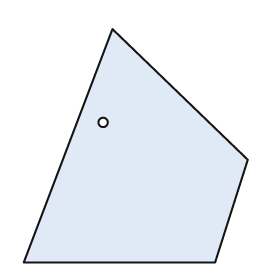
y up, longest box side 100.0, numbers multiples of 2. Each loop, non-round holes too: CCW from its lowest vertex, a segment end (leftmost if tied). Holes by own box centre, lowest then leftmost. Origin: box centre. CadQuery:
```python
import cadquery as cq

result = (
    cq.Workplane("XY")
    .moveTo(-48.0, -50.0)
    .lineTo(34.0, -50.0)
    .lineTo(48.0, -6.0)
    .lineTo(-10.0, 50.0)
    .close()
    .moveTo(-14.0, 10.0)
    .circle(2.0)
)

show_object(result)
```